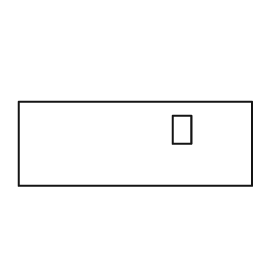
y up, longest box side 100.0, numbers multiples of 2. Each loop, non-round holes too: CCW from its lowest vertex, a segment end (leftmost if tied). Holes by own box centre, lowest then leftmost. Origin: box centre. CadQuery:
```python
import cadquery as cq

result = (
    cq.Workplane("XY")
    .moveTo(-50.0, -18.0)
    .lineTo(50.0, -18.0)
    .lineTo(50.0, 18.0)
    .lineTo(-50.0, 18.0)
    .close()
    .moveTo(16.0, 0.0)
    .lineTo(24.0, 0.0)
    .lineTo(24.0, 12.0)
    .lineTo(16.0, 12.0)
    .close()
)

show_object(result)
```